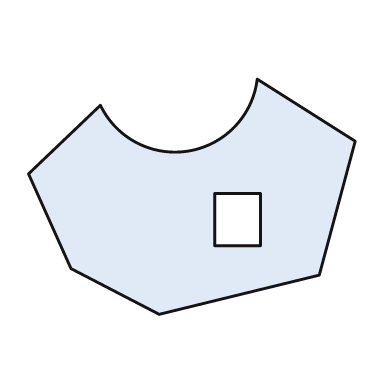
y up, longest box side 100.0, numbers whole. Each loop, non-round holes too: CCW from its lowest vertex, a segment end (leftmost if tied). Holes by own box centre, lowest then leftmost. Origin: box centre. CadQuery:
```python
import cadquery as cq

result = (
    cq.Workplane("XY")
    .moveTo(-10.0, -36.0)
    .lineTo(39.0, -24.0)
    .lineTo(50.0, 17.0)
    .lineTo(20.0, 36.0)
    .threePointArc((-1.0, 14.0), (-28.0, 28.0))
    .lineTo(-50.0, 7.0)
    .lineTo(-37.0, -22.0)
    .close()
    .moveTo(7.0, -15.0)
    .lineTo(21.0, -15.0)
    .lineTo(21.0, 1.0)
    .lineTo(7.0, 1.0)
    .close()
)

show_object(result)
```